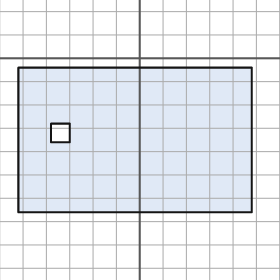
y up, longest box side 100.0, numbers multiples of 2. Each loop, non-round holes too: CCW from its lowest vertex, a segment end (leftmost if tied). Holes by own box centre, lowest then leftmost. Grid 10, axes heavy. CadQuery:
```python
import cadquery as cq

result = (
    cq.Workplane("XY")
    .moveTo(-52.0, -66.0)
    .lineTo(48.0, -66.0)
    .lineTo(48.0, -4.0)
    .lineTo(-52.0, -4.0)
    .close()
    .moveTo(-38.0, -36.0)
    .lineTo(-30.0, -36.0)
    .lineTo(-30.0, -28.0)
    .lineTo(-38.0, -28.0)
    .close()
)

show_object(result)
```